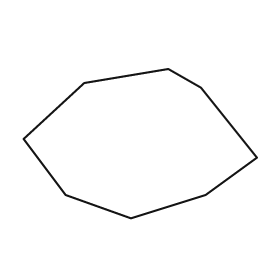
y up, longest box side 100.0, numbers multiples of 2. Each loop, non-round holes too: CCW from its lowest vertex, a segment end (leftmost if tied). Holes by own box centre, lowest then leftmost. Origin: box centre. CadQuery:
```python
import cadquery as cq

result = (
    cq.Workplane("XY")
    .moveTo(-4.0, -32.0)
    .lineTo(28.0, -22.0)
    .lineTo(50.0, -6.0)
    .lineTo(26.0, 24.0)
    .lineTo(12.0, 32.0)
    .lineTo(-24.0, 26.0)
    .lineTo(-50.0, 2.0)
    .lineTo(-32.0, -22.0)
    .close()
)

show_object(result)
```